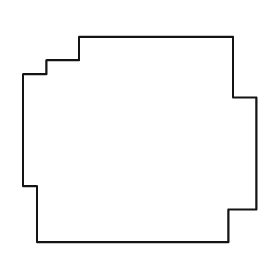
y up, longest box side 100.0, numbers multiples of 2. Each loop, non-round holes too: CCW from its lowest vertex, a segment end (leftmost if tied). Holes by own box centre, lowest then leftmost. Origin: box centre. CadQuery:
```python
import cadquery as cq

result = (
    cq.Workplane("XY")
    .moveTo(-44.0, -44.0)
    .lineTo(38.0, -44.0)
    .lineTo(38.0, -30.0)
    .lineTo(50.0, -30.0)
    .lineTo(50.0, 18.0)
    .lineTo(40.0, 18.0)
    .lineTo(40.0, 44.0)
    .lineTo(-26.0, 44.0)
    .lineTo(-26.0, 34.0)
    .lineTo(-40.0, 34.0)
    .lineTo(-40.0, 28.0)
    .lineTo(-50.0, 28.0)
    .lineTo(-50.0, -20.0)
    .lineTo(-44.0, -20.0)
    .close()
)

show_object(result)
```